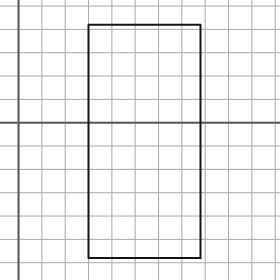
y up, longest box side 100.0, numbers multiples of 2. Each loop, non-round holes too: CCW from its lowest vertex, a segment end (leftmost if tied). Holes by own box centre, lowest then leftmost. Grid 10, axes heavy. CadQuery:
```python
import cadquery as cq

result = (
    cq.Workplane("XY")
    .moveTo(30.0, -58.0)
    .lineTo(78.0, -58.0)
    .lineTo(78.0, 42.0)
    .lineTo(30.0, 42.0)
    .close()
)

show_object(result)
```